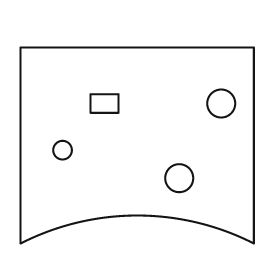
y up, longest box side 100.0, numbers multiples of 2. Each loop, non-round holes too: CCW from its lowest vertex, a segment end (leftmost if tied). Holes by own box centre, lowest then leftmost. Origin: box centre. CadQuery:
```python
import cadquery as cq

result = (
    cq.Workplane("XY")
    .moveTo(-50.0, -42.0)
    .threePointArc((0.0, -30.0), (50.0, -42.0))
    .lineTo(50.0, 42.0)
    .lineTo(-50.0, 42.0)
    .close()
    .moveTo(18.0, -14.0)
    .circle(6.0)
    .moveTo(-32.0, -2.0)
    .circle(4.0)
    .moveTo(-20.0, 14.0)
    .lineTo(-8.0, 14.0)
    .lineTo(-8.0, 22.0)
    .lineTo(-20.0, 22.0)
    .close()
    .moveTo(36.0, 18.0)
    .circle(6.0)
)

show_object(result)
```